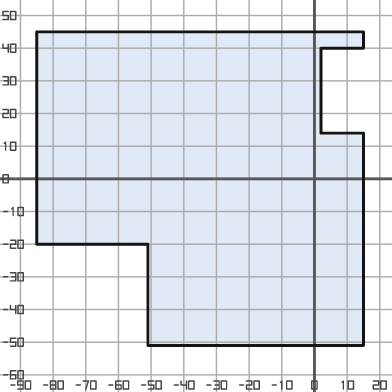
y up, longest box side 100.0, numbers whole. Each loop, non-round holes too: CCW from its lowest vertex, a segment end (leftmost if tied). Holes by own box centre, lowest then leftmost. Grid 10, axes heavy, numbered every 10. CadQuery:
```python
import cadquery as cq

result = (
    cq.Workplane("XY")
    .moveTo(-51.0, -51.0)
    .lineTo(15.0, -51.0)
    .lineTo(15.0, 14.0)
    .lineTo(2.0, 14.0)
    .lineTo(2.0, 40.0)
    .lineTo(15.0, 40.0)
    .lineTo(15.0, 45.0)
    .lineTo(-85.0, 45.0)
    .lineTo(-85.0, -20.0)
    .lineTo(-51.0, -20.0)
    .close()
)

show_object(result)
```